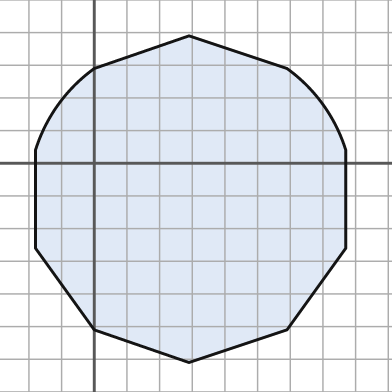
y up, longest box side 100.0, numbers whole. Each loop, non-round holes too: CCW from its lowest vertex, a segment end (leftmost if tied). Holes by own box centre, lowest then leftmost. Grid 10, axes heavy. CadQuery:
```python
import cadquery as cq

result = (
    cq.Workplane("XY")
    .moveTo(29.0, -61.0)
    .lineTo(59.0, -51.0)
    .lineTo(77.0, -26.0)
    .lineTo(77.0, 4.0)
    .threePointArc((70.0, 18.0), (59.0, 29.0))
    .lineTo(29.0, 39.0)
    .lineTo(0.0, 29.0)
    .threePointArc((-11.0, 18.0), (-18.0, 4.0))
    .lineTo(-18.0, -26.0)
    .lineTo(0.0, -51.0)
    .close()
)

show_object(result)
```